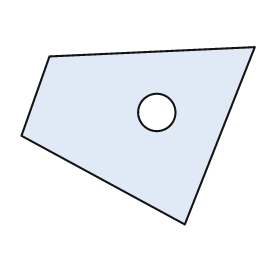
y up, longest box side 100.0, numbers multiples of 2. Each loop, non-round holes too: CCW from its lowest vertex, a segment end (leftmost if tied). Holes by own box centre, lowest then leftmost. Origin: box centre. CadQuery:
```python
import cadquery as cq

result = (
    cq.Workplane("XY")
    .moveTo(20.0, -38.0)
    .lineTo(50.0, 38.0)
    .lineTo(-38.0, 34.0)
    .lineTo(-50.0, 0.0)
    .close()
    .moveTo(8.0, 10.0)
    .circle(8.0)
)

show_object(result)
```